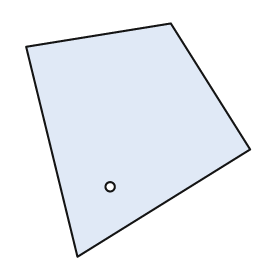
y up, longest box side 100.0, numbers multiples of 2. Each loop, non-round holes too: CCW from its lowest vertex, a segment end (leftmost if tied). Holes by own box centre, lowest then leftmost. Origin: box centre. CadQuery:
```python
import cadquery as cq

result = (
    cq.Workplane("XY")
    .moveTo(-26.0, -50.0)
    .lineTo(48.0, -4.0)
    .lineTo(14.0, 50.0)
    .lineTo(-48.0, 40.0)
    .close()
    .moveTo(-12.0, -20.0)
    .circle(2.0)
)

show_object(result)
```